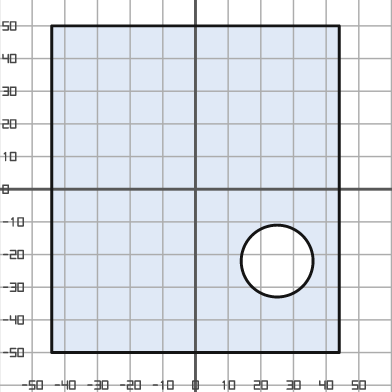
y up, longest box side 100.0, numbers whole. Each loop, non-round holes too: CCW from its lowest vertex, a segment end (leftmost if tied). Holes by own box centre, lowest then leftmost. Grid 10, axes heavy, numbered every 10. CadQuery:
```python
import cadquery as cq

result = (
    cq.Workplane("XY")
    .moveTo(-44.0, -50.0)
    .lineTo(44.0, -50.0)
    .lineTo(44.0, 50.0)
    .lineTo(-44.0, 50.0)
    .close()
    .moveTo(25.0, -22.0)
    .circle(11.0)
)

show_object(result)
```